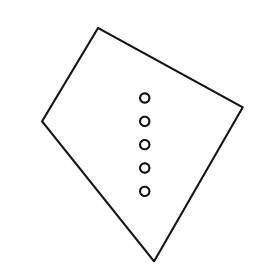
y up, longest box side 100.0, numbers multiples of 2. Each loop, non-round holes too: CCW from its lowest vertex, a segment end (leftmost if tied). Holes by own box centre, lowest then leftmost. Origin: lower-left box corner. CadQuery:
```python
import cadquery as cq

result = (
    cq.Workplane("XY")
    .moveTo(48.0, 0.0)
    .lineTo(86.0, 66.0)
    .lineTo(24.0, 100.0)
    .lineTo(0.0, 60.0)
    .close()
    .moveTo(44.0, 30.0)
    .circle(2.0)
    .moveTo(44.0, 40.0)
    .circle(2.0)
    .moveTo(44.0, 50.0)
    .circle(2.0)
    .moveTo(44.0, 60.0)
    .circle(2.0)
    .moveTo(44.0, 70.0)
    .circle(2.0)
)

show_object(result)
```